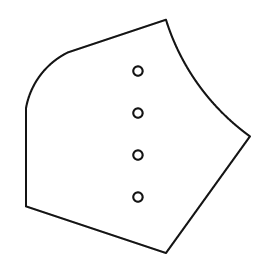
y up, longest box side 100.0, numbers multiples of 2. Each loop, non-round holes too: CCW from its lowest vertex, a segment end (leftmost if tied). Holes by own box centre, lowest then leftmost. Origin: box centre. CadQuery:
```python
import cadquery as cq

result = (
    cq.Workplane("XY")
    .moveTo(12.0, -50.0)
    .lineTo(48.0, 0.0)
    .threePointArc((26.0, 22.0), (12.0, 50.0))
    .lineTo(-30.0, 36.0)
    .threePointArc((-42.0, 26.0), (-48.0, 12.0))
    .lineTo(-48.0, -30.0)
    .close()
    .moveTo(0.0, -26.0)
    .circle(2.0)
    .moveTo(0.0, -8.0)
    .circle(2.0)
    .moveTo(0.0, 10.0)
    .circle(2.0)
    .moveTo(0.0, 28.0)
    .circle(2.0)
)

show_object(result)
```